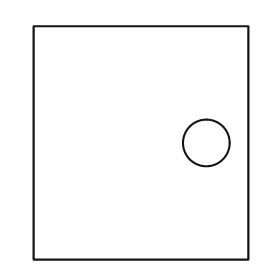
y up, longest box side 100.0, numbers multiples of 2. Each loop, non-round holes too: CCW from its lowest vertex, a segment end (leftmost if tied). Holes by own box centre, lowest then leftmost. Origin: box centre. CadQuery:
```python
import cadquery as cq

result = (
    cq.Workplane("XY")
    .moveTo(-46.0, -50.0)
    .lineTo(46.0, -50.0)
    .lineTo(46.0, 50.0)
    .lineTo(-46.0, 50.0)
    .close()
    .moveTo(28.0, 0.0)
    .circle(10.0)
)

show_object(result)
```